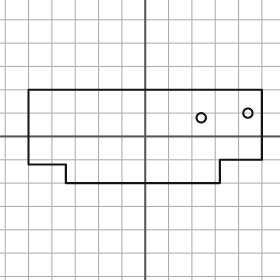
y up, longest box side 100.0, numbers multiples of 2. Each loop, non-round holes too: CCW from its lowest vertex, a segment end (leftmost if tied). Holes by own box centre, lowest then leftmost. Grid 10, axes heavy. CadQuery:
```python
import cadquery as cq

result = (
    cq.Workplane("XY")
    .moveTo(-34.0, -20.0)
    .lineTo(32.0, -20.0)
    .lineTo(32.0, -10.0)
    .lineTo(50.0, -10.0)
    .lineTo(50.0, 20.0)
    .lineTo(-50.0, 20.0)
    .lineTo(-50.0, -12.0)
    .lineTo(-34.0, -12.0)
    .close()
    .moveTo(24.0, 8.0)
    .circle(2.0)
    .moveTo(44.0, 10.0)
    .circle(2.0)
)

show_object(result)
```